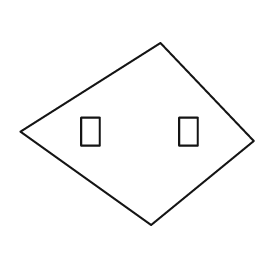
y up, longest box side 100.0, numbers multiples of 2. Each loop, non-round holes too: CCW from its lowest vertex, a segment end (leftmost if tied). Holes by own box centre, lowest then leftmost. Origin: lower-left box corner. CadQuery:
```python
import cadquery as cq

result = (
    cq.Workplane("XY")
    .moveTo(56.0, 0.0)
    .lineTo(100.0, 36.0)
    .lineTo(60.0, 78.0)
    .lineTo(0.0, 40.0)
    .close()
    .moveTo(26.0, 34.0)
    .lineTo(34.0, 34.0)
    .lineTo(34.0, 46.0)
    .lineTo(26.0, 46.0)
    .close()
    .moveTo(68.0, 34.0)
    .lineTo(76.0, 34.0)
    .lineTo(76.0, 46.0)
    .lineTo(68.0, 46.0)
    .close()
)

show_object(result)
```